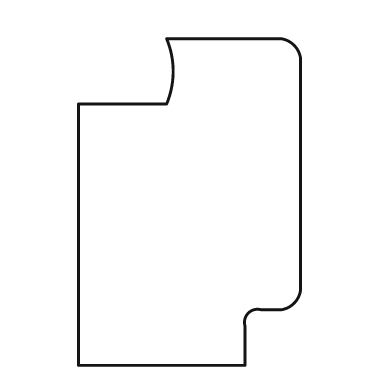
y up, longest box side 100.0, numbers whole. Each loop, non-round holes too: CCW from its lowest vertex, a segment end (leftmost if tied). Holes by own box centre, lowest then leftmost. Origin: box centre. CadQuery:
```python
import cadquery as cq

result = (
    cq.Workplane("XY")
    .moveTo(-34.0, -50.0)
    .lineTo(17.0, -50.0)
    .lineTo(17.0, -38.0)
    .threePointArc((18.0, -34.0), (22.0, -33.0))
    .lineTo(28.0, -33.0)
    .threePointArc((32.0, -31.0), (34.0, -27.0))
    .lineTo(34.0, 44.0)
    .threePointArc((32.0, 48.0), (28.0, 50.0))
    .lineTo(-7.0, 50.0)
    .threePointArc((-5.0, 40.0), (-7.0, 30.0))
    .lineTo(-34.0, 30.0)
    .close()
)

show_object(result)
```